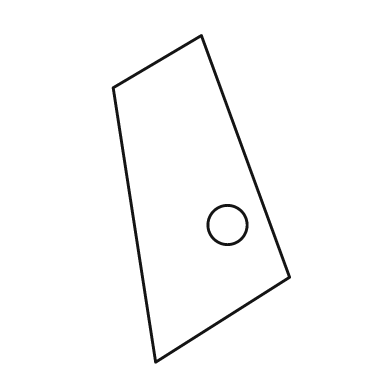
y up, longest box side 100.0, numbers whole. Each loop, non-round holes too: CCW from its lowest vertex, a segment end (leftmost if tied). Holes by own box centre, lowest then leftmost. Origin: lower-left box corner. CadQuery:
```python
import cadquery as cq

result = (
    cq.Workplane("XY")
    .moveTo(13.0, 0.0)
    .lineTo(54.0, 26.0)
    .lineTo(27.0, 100.0)
    .lineTo(0.0, 84.0)
    .close()
    .moveTo(35.0, 42.0)
    .circle(6.0)
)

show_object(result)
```